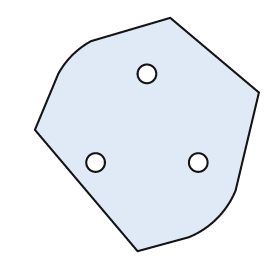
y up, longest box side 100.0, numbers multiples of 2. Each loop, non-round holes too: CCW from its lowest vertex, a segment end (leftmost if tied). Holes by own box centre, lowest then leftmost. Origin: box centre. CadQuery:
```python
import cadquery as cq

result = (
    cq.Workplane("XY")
    .moveTo(-4.0, -50.0)
    .lineTo(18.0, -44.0)
    .threePointArc((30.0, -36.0), (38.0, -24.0))
    .lineTo(48.0, 18.0)
    .lineTo(10.0, 50.0)
    .lineTo(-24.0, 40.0)
    .threePointArc((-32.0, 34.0), (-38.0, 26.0))
    .lineTo(-48.0, 2.0)
    .close()
    .moveTo(-22.0, -12.0)
    .circle(4.0)
    .moveTo(22.0, -12.0)
    .circle(4.0)
    .moveTo(0.0, 26.0)
    .circle(4.0)
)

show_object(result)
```